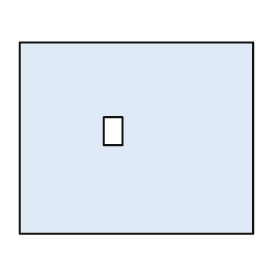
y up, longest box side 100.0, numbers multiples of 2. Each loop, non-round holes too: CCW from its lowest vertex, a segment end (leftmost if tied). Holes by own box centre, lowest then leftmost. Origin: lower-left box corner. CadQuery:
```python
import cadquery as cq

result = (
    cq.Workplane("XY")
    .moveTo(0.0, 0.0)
    .lineTo(100.0, 0.0)
    .lineTo(100.0, 82.0)
    .lineTo(0.0, 82.0)
    .close()
    .moveTo(36.0, 38.0)
    .lineTo(44.0, 38.0)
    .lineTo(44.0, 50.0)
    .lineTo(36.0, 50.0)
    .close()
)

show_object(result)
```